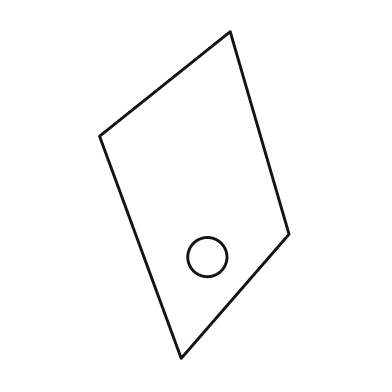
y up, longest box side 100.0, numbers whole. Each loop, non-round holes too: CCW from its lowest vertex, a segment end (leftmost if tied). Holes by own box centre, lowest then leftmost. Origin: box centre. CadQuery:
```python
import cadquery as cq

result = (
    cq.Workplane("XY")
    .moveTo(-4.0, -50.0)
    .lineTo(29.0, -12.0)
    .lineTo(11.0, 50.0)
    .lineTo(-29.0, 18.0)
    .close()
    .moveTo(4.0, -19.0)
    .circle(6.0)
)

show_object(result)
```